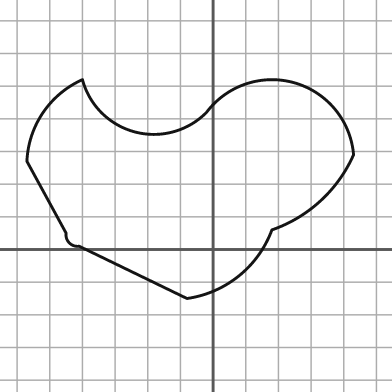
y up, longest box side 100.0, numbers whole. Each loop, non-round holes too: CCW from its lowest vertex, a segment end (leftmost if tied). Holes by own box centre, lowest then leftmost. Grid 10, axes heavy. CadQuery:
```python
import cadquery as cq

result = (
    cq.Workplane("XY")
    .moveTo(-8.0, -15.0)
    .threePointArc((8.0, -8.0), (18.0, 6.0))
    .threePointArc((33.0, 15.0), (43.0, 29.0))
    .threePointArc((25.0, 51.0), (-2.0, 42.0))
    .threePointArc((-24.0, 36.0), (-40.0, 52.0))
    .threePointArc((-52.0, 42.0), (-57.0, 27.0))
    .lineTo(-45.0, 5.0)
    .threePointArc((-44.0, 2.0), (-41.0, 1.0))
    .close()
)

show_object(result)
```